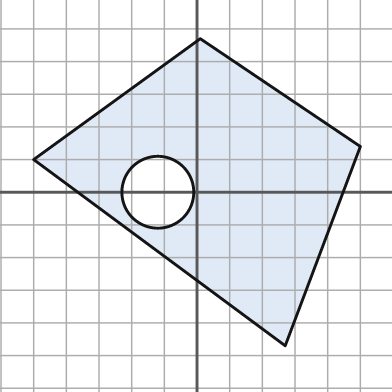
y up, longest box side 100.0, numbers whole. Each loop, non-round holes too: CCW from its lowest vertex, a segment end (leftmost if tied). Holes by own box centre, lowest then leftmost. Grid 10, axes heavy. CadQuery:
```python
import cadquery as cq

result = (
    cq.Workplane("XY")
    .moveTo(27.0, -47.0)
    .lineTo(50.0, 14.0)
    .lineTo(1.0, 47.0)
    .lineTo(-50.0, 10.0)
    .close()
    .moveTo(-12.0, 0.0)
    .circle(11.0)
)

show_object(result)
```